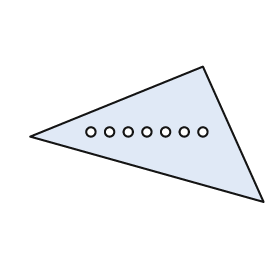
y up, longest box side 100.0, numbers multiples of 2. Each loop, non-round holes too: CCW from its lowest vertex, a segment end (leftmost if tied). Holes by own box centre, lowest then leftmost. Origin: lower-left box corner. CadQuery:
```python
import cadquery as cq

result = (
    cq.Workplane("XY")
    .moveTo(100.0, 0.0)
    .lineTo(74.0, 58.0)
    .lineTo(0.0, 28.0)
    .close()
    .moveTo(26.0, 30.0)
    .circle(2.0)
    .moveTo(34.0, 30.0)
    .circle(2.0)
    .moveTo(42.0, 30.0)
    .circle(2.0)
    .moveTo(50.0, 30.0)
    .circle(2.0)
    .moveTo(58.0, 30.0)
    .circle(2.0)
    .moveTo(66.0, 30.0)
    .circle(2.0)
    .moveTo(74.0, 30.0)
    .circle(2.0)
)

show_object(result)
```